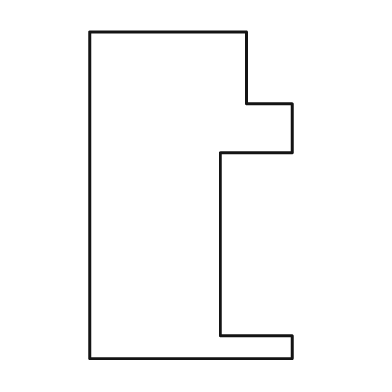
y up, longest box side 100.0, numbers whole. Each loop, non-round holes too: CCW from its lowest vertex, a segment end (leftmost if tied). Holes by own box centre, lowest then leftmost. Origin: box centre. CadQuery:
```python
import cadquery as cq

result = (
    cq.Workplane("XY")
    .moveTo(-31.0, -50.0)
    .lineTo(31.0, -50.0)
    .lineTo(31.0, -43.0)
    .lineTo(9.0, -43.0)
    .lineTo(9.0, 13.0)
    .lineTo(31.0, 13.0)
    .lineTo(31.0, 28.0)
    .lineTo(17.0, 28.0)
    .lineTo(17.0, 50.0)
    .lineTo(-31.0, 50.0)
    .close()
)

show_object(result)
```